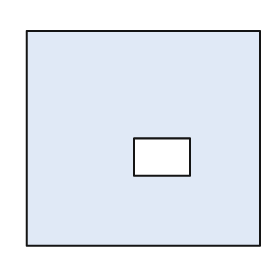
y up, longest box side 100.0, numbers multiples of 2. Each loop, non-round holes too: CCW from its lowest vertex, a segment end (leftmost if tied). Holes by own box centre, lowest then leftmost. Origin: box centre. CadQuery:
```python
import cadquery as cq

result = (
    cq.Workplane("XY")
    .moveTo(-50.0, -46.0)
    .lineTo(50.0, -46.0)
    .lineTo(50.0, 46.0)
    .lineTo(-50.0, 46.0)
    .close()
    .moveTo(-4.0, -16.0)
    .lineTo(20.0, -16.0)
    .lineTo(20.0, 0.0)
    .lineTo(-4.0, 0.0)
    .close()
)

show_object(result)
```